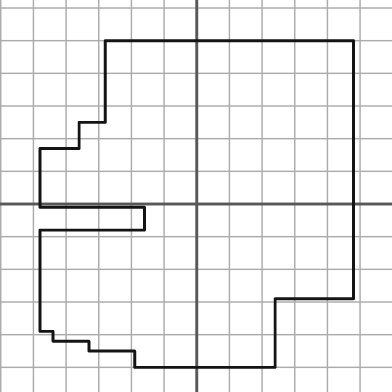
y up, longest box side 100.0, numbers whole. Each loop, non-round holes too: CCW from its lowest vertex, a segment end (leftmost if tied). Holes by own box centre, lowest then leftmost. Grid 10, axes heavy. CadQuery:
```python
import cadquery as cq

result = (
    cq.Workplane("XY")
    .moveTo(-19.0, -50.0)
    .lineTo(24.0, -50.0)
    .lineTo(24.0, -29.0)
    .lineTo(48.0, -29.0)
    .lineTo(48.0, 50.0)
    .lineTo(-28.0, 50.0)
    .lineTo(-28.0, 25.0)
    .lineTo(-36.0, 25.0)
    .lineTo(-36.0, 17.0)
    .lineTo(-48.0, 17.0)
    .lineTo(-48.0, -1.0)
    .lineTo(-16.0, -1.0)
    .lineTo(-16.0, -8.0)
    .lineTo(-48.0, -8.0)
    .lineTo(-48.0, -39.0)
    .lineTo(-44.0, -39.0)
    .lineTo(-44.0, -42.0)
    .lineTo(-33.0, -42.0)
    .lineTo(-33.0, -45.0)
    .lineTo(-19.0, -45.0)
    .close()
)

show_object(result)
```